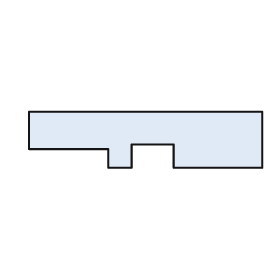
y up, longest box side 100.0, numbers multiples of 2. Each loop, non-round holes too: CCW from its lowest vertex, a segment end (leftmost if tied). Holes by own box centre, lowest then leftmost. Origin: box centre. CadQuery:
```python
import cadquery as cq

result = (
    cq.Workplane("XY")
    .moveTo(-16.0, -12.0)
    .lineTo(-6.0, -12.0)
    .lineTo(-6.0, -2.0)
    .lineTo(12.0, -2.0)
    .lineTo(12.0, -12.0)
    .lineTo(50.0, -12.0)
    .lineTo(50.0, 12.0)
    .lineTo(-50.0, 12.0)
    .lineTo(-50.0, -4.0)
    .lineTo(-16.0, -4.0)
    .close()
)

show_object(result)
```